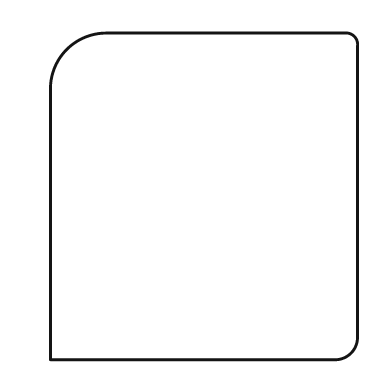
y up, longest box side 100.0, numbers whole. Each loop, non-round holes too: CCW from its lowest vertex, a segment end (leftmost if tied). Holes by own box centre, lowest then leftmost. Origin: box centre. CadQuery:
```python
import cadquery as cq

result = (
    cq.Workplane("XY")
    .moveTo(-47.0, -50.0)
    .lineTo(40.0, -50.0)
    .threePointArc((45.0, -48.0), (47.0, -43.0))
    .lineTo(47.0, 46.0)
    .threePointArc((46.0, 49.0), (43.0, 50.0))
    .lineTo(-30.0, 50.0)
    .threePointArc((-42.0, 45.0), (-47.0, 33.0))
    .close()
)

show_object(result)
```